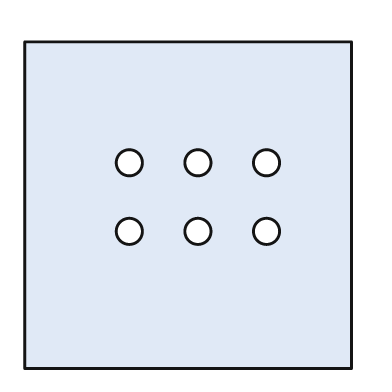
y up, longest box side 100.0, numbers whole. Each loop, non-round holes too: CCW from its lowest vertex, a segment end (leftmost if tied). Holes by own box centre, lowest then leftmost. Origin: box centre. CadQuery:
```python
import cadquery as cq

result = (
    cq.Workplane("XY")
    .moveTo(-50.0, -50.0)
    .lineTo(50.0, -50.0)
    .lineTo(50.0, 50.0)
    .lineTo(-50.0, 50.0)
    .close()
    .moveTo(-18.0, -8.0)
    .circle(4.0)
    .moveTo(3.0, -8.0)
    .circle(4.0)
    .moveTo(24.0, -8.0)
    .circle(4.0)
    .moveTo(-18.0, 13.0)
    .circle(4.0)
    .moveTo(3.0, 13.0)
    .circle(4.0)
    .moveTo(24.0, 13.0)
    .circle(4.0)
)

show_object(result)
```